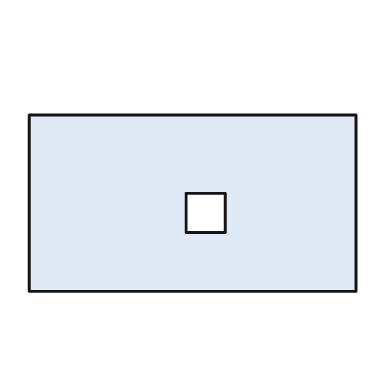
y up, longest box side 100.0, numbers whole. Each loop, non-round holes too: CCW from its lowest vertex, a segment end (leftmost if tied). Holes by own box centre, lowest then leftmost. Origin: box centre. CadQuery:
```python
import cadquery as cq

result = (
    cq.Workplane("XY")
    .moveTo(-50.0, -27.0)
    .lineTo(50.0, -27.0)
    .lineTo(50.0, 27.0)
    .lineTo(-50.0, 27.0)
    .close()
    .moveTo(-2.0, -9.0)
    .lineTo(10.0, -9.0)
    .lineTo(10.0, 3.0)
    .lineTo(-2.0, 3.0)
    .close()
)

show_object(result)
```